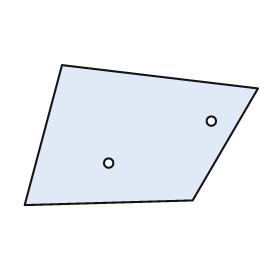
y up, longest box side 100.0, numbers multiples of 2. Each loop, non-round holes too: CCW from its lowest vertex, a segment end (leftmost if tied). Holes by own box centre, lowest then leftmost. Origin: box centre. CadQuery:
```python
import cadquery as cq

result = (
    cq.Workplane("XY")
    .moveTo(-50.0, -30.0)
    .lineTo(22.0, -28.0)
    .lineTo(50.0, 20.0)
    .lineTo(-34.0, 30.0)
    .close()
    .moveTo(-14.0, -12.0)
    .circle(2.0)
    .moveTo(30.0, 6.0)
    .circle(2.0)
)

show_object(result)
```